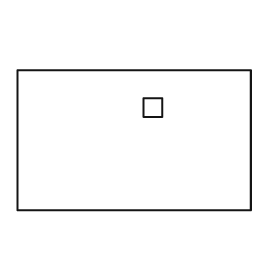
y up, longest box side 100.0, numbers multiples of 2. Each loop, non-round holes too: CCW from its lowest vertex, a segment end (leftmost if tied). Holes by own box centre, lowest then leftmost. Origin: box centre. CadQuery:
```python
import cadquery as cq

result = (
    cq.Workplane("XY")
    .moveTo(-50.0, -30.0)
    .lineTo(50.0, -30.0)
    .lineTo(50.0, 30.0)
    .lineTo(-50.0, 30.0)
    .close()
    .moveTo(4.0, 10.0)
    .lineTo(12.0, 10.0)
    .lineTo(12.0, 18.0)
    .lineTo(4.0, 18.0)
    .close()
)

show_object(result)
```